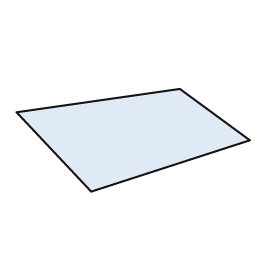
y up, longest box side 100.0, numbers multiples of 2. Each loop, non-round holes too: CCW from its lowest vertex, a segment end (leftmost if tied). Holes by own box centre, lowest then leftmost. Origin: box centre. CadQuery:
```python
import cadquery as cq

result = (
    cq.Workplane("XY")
    .moveTo(-18.0, -22.0)
    .lineTo(50.0, 0.0)
    .lineTo(20.0, 22.0)
    .lineTo(-50.0, 12.0)
    .close()
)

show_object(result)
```